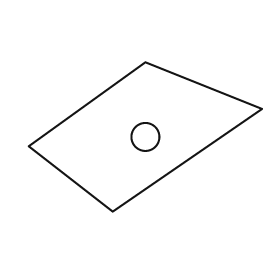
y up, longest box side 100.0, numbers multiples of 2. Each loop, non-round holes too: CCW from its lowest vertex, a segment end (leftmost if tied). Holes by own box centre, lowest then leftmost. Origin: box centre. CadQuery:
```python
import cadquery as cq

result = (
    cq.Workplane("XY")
    .moveTo(-14.0, -32.0)
    .lineTo(50.0, 12.0)
    .lineTo(0.0, 32.0)
    .lineTo(-50.0, -4.0)
    .close()
    .moveTo(0.0, 0.0)
    .circle(6.0)
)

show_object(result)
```